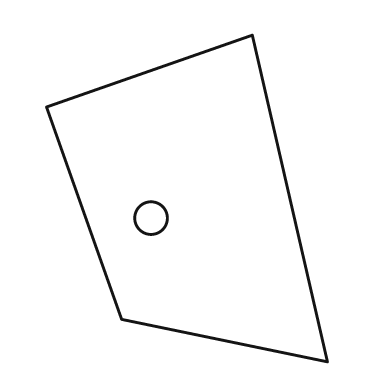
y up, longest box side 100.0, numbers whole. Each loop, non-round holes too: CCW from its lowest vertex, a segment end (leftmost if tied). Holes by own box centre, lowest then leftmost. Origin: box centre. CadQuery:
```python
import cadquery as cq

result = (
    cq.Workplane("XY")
    .moveTo(43.0, -50.0)
    .lineTo(20.0, 50.0)
    .lineTo(-43.0, 28.0)
    .lineTo(-20.0, -37.0)
    .close()
    .moveTo(-11.0, -6.0)
    .circle(5.0)
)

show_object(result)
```